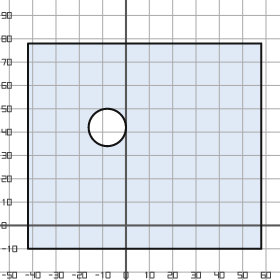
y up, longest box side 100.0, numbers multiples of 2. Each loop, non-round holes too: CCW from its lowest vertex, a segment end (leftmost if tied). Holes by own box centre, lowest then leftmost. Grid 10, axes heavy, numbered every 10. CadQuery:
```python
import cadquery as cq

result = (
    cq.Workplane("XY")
    .moveTo(-42.0, -10.0)
    .lineTo(58.0, -10.0)
    .lineTo(58.0, 78.0)
    .lineTo(-42.0, 78.0)
    .close()
    .moveTo(-8.0, 42.0)
    .circle(8.0)
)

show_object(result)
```